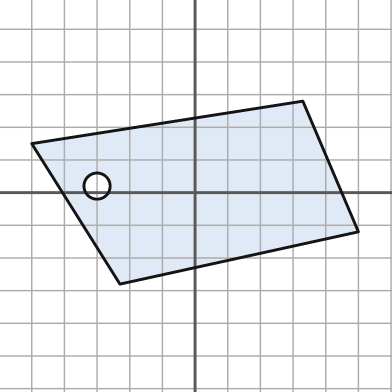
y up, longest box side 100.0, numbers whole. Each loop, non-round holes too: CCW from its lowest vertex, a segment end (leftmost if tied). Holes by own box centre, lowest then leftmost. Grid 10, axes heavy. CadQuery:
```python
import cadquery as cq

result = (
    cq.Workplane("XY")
    .moveTo(-23.0, -28.0)
    .lineTo(50.0, -12.0)
    .lineTo(33.0, 28.0)
    .lineTo(-50.0, 15.0)
    .close()
    .moveTo(-30.0, 2.0)
    .circle(4.0)
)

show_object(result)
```